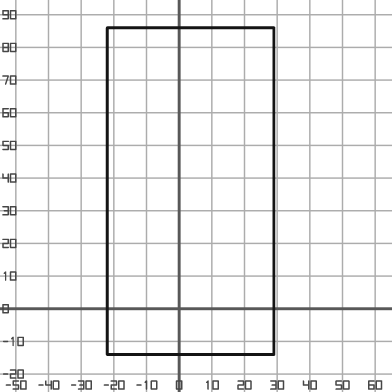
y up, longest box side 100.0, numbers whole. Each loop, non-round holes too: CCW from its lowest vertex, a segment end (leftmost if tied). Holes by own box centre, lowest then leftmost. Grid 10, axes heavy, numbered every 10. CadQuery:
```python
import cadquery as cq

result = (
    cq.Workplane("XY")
    .moveTo(-22.0, -14.0)
    .lineTo(29.0, -14.0)
    .lineTo(29.0, 86.0)
    .lineTo(-22.0, 86.0)
    .close()
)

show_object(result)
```